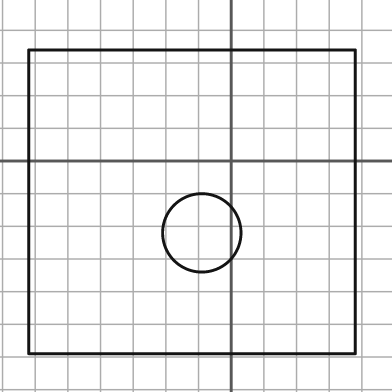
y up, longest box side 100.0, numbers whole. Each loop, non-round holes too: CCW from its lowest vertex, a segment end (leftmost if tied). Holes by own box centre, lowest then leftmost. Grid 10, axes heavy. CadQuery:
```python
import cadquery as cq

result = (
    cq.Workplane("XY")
    .moveTo(-62.0, -59.0)
    .lineTo(38.0, -59.0)
    .lineTo(38.0, 34.0)
    .lineTo(-62.0, 34.0)
    .close()
    .moveTo(-9.0, -22.0)
    .circle(12.0)
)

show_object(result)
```